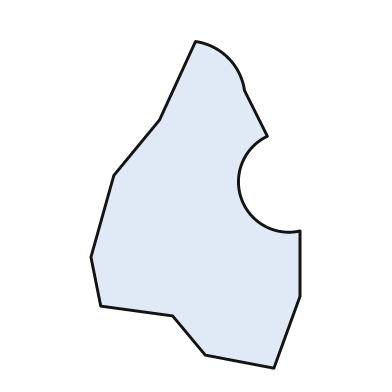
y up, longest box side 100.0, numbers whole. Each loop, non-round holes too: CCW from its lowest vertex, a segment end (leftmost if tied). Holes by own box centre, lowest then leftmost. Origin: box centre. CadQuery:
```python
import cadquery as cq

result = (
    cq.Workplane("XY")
    .moveTo(24.0, -50.0)
    .lineTo(32.0, -28.0)
    .lineTo(32.0, -8.0)
    .threePointArc((14.0, 2.0), (22.0, 21.0))
    .lineTo(15.0, 35.0)
    .threePointArc((10.0, 45.0), (0.0, 50.0))
    .lineTo(-11.0, 26.0)
    .lineTo(-25.0, 9.0)
    .lineTo(-32.0, -16.0)
    .lineTo(-29.0, -31.0)
    .lineTo(-7.0, -34.0)
    .lineTo(3.0, -46.0)
    .close()
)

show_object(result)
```